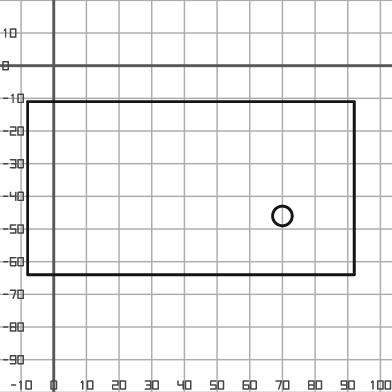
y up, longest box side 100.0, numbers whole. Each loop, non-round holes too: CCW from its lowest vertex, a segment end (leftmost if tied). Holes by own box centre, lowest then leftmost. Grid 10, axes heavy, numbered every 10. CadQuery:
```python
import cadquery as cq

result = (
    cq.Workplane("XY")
    .moveTo(-8.0, -64.0)
    .lineTo(92.0, -64.0)
    .lineTo(92.0, -11.0)
    .lineTo(-8.0, -11.0)
    .close()
    .moveTo(70.0, -46.0)
    .circle(3.0)
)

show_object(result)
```